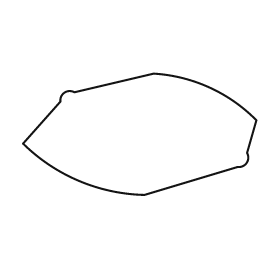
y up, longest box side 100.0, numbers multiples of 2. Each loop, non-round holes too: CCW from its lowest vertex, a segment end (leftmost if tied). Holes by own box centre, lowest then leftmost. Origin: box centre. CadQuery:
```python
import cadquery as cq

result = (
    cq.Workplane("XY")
    .moveTo(2.0, -26.0)
    .lineTo(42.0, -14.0)
    .threePointArc((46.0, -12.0), (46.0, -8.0))
    .lineTo(50.0, 6.0)
    .threePointArc((30.0, 20.0), (6.0, 26.0))
    .lineTo(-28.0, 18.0)
    .threePointArc((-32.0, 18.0), (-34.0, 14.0))
    .lineTo(-50.0, -4.0)
    .threePointArc((-26.0, -20.0), (2.0, -26.0))
    .close()
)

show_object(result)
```